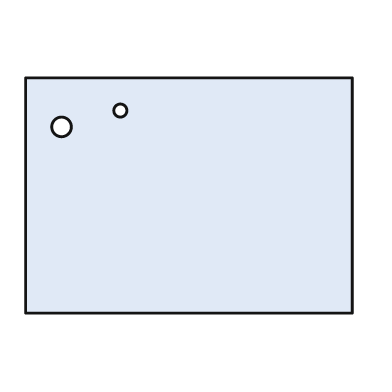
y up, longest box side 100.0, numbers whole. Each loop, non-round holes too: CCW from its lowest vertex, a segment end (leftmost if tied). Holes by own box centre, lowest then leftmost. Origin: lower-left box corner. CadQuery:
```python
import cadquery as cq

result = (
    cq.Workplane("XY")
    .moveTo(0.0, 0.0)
    .lineTo(100.0, 0.0)
    .lineTo(100.0, 72.0)
    .lineTo(0.0, 72.0)
    .close()
    .moveTo(11.0, 57.0)
    .circle(3.0)
    .moveTo(29.0, 62.0)
    .circle(2.0)
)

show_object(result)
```